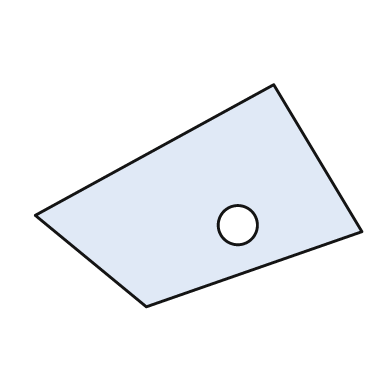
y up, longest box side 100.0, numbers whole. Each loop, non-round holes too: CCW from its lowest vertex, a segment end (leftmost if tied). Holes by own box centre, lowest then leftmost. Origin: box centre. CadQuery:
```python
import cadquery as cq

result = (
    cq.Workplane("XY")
    .moveTo(-16.0, -34.0)
    .lineTo(50.0, -11.0)
    .lineTo(23.0, 34.0)
    .lineTo(-50.0, -6.0)
    .close()
    .moveTo(12.0, -9.0)
    .circle(6.0)
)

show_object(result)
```